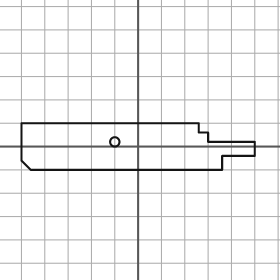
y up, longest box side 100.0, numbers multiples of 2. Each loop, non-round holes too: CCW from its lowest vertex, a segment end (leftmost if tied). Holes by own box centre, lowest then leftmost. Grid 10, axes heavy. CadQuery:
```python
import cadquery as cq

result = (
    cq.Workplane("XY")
    .moveTo(-46.0, -10.0)
    .lineTo(36.0, -10.0)
    .lineTo(36.0, -4.0)
    .lineTo(50.0, -4.0)
    .lineTo(50.0, 2.0)
    .lineTo(30.0, 2.0)
    .lineTo(30.0, 6.0)
    .lineTo(26.0, 6.0)
    .lineTo(26.0, 10.0)
    .lineTo(-50.0, 10.0)
    .lineTo(-50.0, -6.0)
    .close()
    .moveTo(-10.0, 2.0)
    .circle(2.0)
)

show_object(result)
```